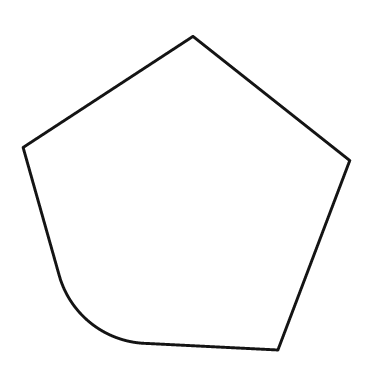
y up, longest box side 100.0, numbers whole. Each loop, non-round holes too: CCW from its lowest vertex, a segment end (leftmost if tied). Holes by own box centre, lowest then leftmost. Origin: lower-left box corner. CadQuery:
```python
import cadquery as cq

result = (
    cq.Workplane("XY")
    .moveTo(78.0, 0.0)
    .lineTo(100.0, 58.0)
    .lineTo(52.0, 96.0)
    .lineTo(0.0, 62.0)
    .lineTo(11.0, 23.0)
    .threePointArc((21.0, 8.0), (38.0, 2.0))
    .close()
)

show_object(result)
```